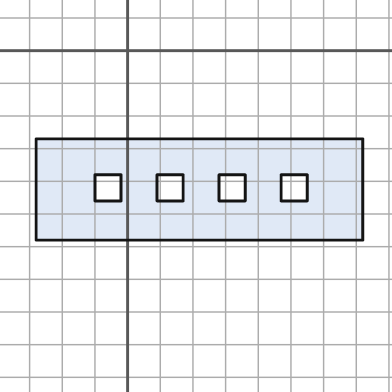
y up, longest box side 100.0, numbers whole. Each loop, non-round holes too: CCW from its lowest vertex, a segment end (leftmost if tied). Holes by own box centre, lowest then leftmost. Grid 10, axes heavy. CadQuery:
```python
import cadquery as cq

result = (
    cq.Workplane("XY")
    .moveTo(-28.0, -58.0)
    .lineTo(72.0, -58.0)
    .lineTo(72.0, -27.0)
    .lineTo(-28.0, -27.0)
    .close()
    .moveTo(-10.0, -46.0)
    .lineTo(-2.0, -46.0)
    .lineTo(-2.0, -38.0)
    .lineTo(-10.0, -38.0)
    .close()
    .moveTo(9.0, -46.0)
    .lineTo(17.0, -46.0)
    .lineTo(17.0, -38.0)
    .lineTo(9.0, -38.0)
    .close()
    .moveTo(28.0, -46.0)
    .lineTo(36.0, -46.0)
    .lineTo(36.0, -38.0)
    .lineTo(28.0, -38.0)
    .close()
    .moveTo(47.0, -46.0)
    .lineTo(55.0, -46.0)
    .lineTo(55.0, -38.0)
    .lineTo(47.0, -38.0)
    .close()
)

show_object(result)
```